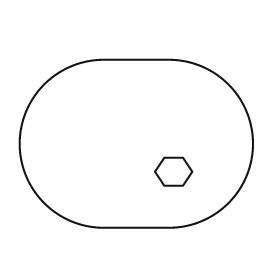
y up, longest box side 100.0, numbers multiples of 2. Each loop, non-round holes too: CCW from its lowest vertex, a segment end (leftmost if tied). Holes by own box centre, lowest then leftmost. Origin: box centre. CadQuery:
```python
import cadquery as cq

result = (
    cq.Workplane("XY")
    .moveTo(-14.0, -36.0)
    .lineTo(14.0, -36.0)
    .threePointArc((50.0, 0.0), (14.0, 36.0))
    .lineTo(-14.0, 36.0)
    .threePointArc((-50.0, 0.0), (-14.0, -36.0))
    .close()
    .moveTo(12.0, -18.0)
    .lineTo(20.0, -18.0)
    .lineTo(24.0, -12.0)
    .lineTo(20.0, -6.0)
    .lineTo(12.0, -6.0)
    .lineTo(8.0, -12.0)
    .close()
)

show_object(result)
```